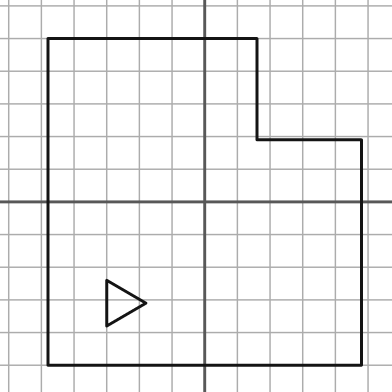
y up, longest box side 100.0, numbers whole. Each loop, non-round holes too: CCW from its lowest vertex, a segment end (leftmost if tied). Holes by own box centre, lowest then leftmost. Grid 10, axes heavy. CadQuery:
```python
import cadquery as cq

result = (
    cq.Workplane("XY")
    .moveTo(-48.0, -50.0)
    .lineTo(48.0, -50.0)
    .lineTo(48.0, 19.0)
    .lineTo(16.0, 19.0)
    .lineTo(16.0, 50.0)
    .lineTo(-48.0, 50.0)
    .close()
    .moveTo(-30.0, -38.0)
    .lineTo(-18.0, -31.0)
    .lineTo(-30.0, -24.0)
    .close()
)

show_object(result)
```